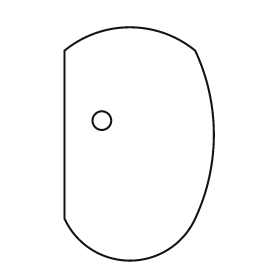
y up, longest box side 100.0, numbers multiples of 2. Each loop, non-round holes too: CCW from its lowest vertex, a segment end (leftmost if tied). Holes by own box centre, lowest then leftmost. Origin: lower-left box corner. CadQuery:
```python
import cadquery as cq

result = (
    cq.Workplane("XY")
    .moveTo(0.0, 18.0)
    .threePointArc((28.0, 0.0), (56.0, 18.0))
    .threePointArc((64.0, 54.0), (56.0, 90.0))
    .threePointArc((28.0, 100.0), (0.0, 90.0))
    .close()
    .moveTo(16.0, 60.0)
    .circle(4.0)
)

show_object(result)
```